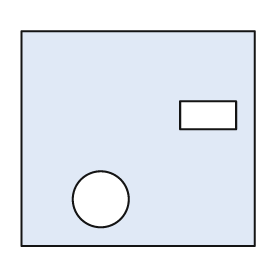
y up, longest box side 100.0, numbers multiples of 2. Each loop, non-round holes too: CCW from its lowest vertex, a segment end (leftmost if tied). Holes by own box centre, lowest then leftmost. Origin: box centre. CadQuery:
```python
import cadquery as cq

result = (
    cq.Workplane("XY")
    .moveTo(-50.0, -46.0)
    .lineTo(50.0, -46.0)
    .lineTo(50.0, 46.0)
    .lineTo(-50.0, 46.0)
    .close()
    .moveTo(-16.0, -26.0)
    .circle(12.0)
    .moveTo(18.0, 4.0)
    .lineTo(42.0, 4.0)
    .lineTo(42.0, 16.0)
    .lineTo(18.0, 16.0)
    .close()
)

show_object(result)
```